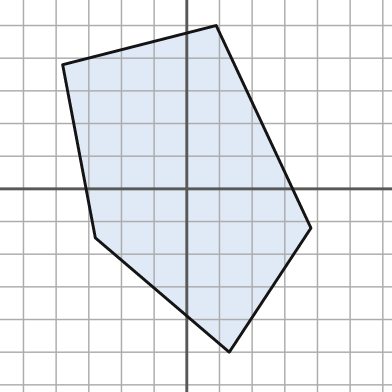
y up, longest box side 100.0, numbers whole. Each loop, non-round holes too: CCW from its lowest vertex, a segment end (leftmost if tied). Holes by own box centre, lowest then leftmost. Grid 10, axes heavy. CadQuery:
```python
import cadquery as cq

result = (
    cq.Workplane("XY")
    .moveTo(13.0, -50.0)
    .lineTo(38.0, -12.0)
    .lineTo(9.0, 50.0)
    .lineTo(-38.0, 38.0)
    .lineTo(-28.0, -15.0)
    .close()
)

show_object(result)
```